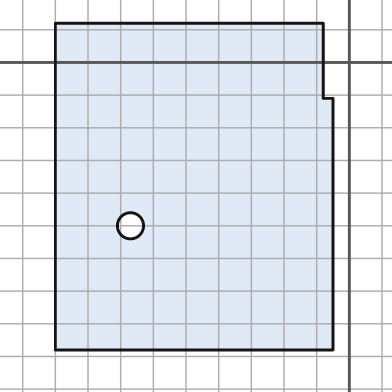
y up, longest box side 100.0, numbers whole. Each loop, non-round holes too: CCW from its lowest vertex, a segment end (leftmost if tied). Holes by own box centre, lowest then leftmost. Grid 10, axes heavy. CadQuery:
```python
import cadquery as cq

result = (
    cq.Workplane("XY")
    .moveTo(-90.0, -88.0)
    .lineTo(-5.0, -88.0)
    .lineTo(-5.0, -11.0)
    .lineTo(-8.0, -11.0)
    .lineTo(-8.0, 12.0)
    .lineTo(-90.0, 12.0)
    .close()
    .moveTo(-67.0, -50.0)
    .circle(4.0)
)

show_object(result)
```